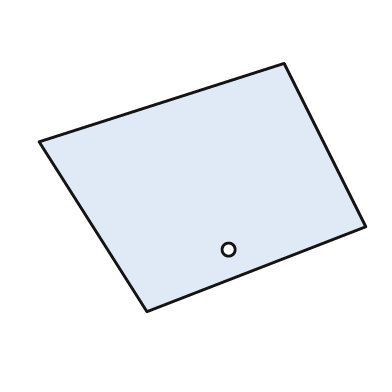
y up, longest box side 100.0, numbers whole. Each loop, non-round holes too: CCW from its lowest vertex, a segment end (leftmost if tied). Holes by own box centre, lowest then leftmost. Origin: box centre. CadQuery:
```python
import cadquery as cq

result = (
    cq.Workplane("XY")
    .moveTo(-17.0, -38.0)
    .lineTo(50.0, -12.0)
    .lineTo(25.0, 38.0)
    .lineTo(-50.0, 14.0)
    .close()
    .moveTo(8.0, -19.0)
    .circle(2.0)
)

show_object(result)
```